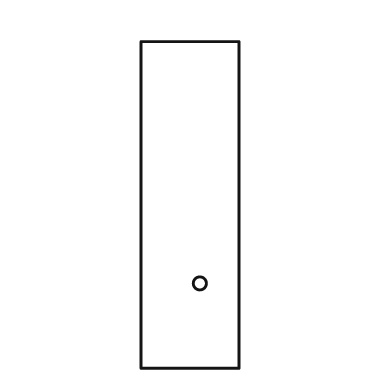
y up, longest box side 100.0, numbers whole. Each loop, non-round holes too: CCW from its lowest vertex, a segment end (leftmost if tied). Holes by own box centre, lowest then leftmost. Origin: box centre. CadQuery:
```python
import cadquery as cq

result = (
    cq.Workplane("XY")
    .moveTo(-15.0, -50.0)
    .lineTo(15.0, -50.0)
    .lineTo(15.0, 50.0)
    .lineTo(-15.0, 50.0)
    .close()
    .moveTo(3.0, -24.0)
    .circle(2.0)
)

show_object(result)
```